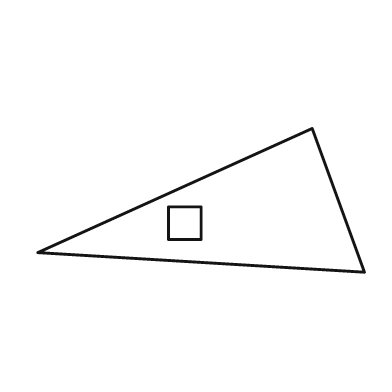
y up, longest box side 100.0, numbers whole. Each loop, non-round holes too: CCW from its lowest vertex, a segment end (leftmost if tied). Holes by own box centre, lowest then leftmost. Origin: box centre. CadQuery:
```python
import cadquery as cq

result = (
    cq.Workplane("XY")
    .moveTo(50.0, -22.0)
    .lineTo(34.0, 22.0)
    .lineTo(-50.0, -16.0)
    .close()
    .moveTo(-10.0, -12.0)
    .lineTo(0.0, -12.0)
    .lineTo(0.0, -2.0)
    .lineTo(-10.0, -2.0)
    .close()
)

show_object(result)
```